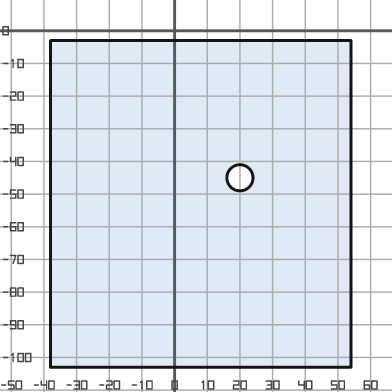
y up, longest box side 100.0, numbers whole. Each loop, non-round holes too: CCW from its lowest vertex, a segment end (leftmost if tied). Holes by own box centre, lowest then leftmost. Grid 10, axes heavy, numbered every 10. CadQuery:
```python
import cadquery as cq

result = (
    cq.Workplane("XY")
    .moveTo(-38.0, -103.0)
    .lineTo(54.0, -103.0)
    .lineTo(54.0, -3.0)
    .lineTo(-38.0, -3.0)
    .close()
    .moveTo(20.0, -45.0)
    .circle(4.0)
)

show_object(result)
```